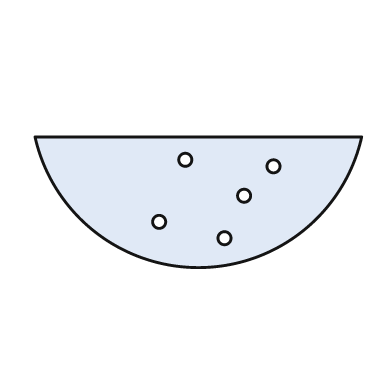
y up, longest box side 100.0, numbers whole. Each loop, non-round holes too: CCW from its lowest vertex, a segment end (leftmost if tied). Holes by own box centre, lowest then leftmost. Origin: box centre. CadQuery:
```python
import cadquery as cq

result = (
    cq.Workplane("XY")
    .moveTo(-50.0, 20.0)
    .threePointArc((0.0, -20.0), (50.0, 20.0))
    .close()
    .moveTo(8.0, -11.0)
    .circle(2.0)
    .moveTo(-12.0, -6.0)
    .circle(2.0)
    .moveTo(14.0, 2.0)
    .circle(2.0)
    .moveTo(23.0, 11.0)
    .circle(2.0)
    .moveTo(-4.0, 13.0)
    .circle(2.0)
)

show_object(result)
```